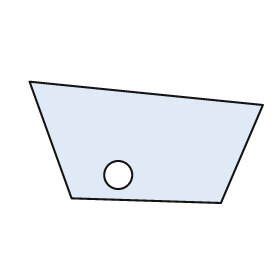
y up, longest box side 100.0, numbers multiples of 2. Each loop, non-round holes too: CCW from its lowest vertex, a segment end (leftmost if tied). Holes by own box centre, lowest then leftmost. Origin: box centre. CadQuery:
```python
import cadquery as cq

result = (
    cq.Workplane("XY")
    .moveTo(32.0, -26.0)
    .lineTo(50.0, 16.0)
    .lineTo(-50.0, 26.0)
    .lineTo(-32.0, -24.0)
    .close()
    .moveTo(-12.0, -14.0)
    .circle(6.0)
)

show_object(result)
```